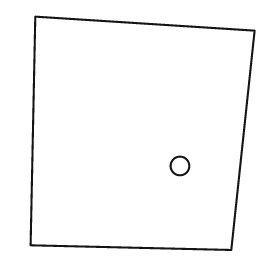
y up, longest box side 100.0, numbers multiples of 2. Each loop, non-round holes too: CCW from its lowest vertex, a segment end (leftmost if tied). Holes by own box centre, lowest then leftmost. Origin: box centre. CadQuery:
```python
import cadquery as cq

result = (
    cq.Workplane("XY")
    .moveTo(38.0, -50.0)
    .lineTo(48.0, 44.0)
    .lineTo(-46.0, 50.0)
    .lineTo(-48.0, -48.0)
    .close()
    .moveTo(16.0, -14.0)
    .circle(4.0)
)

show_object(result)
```